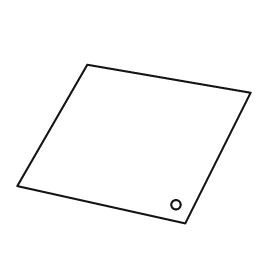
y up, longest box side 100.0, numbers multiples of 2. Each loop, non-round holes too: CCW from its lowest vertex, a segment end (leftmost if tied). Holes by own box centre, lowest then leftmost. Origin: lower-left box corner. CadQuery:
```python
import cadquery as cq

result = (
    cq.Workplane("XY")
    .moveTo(72.0, 0.0)
    .lineTo(100.0, 56.0)
    .lineTo(30.0, 68.0)
    .lineTo(0.0, 16.0)
    .close()
    .moveTo(68.0, 8.0)
    .circle(2.0)
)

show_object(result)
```